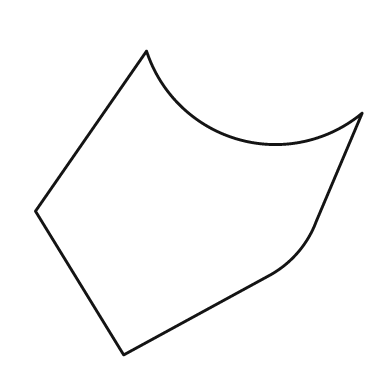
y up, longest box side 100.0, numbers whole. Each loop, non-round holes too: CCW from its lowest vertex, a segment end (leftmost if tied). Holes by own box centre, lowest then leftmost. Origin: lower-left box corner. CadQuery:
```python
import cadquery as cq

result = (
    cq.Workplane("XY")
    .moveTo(27.0, 0.0)
    .lineTo(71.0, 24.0)
    .threePointArc((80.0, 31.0), (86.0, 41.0))
    .lineTo(100.0, 74.0)
    .threePointArc((62.0, 66.0), (34.0, 93.0))
    .lineTo(0.0, 44.0)
    .close()
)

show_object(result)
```